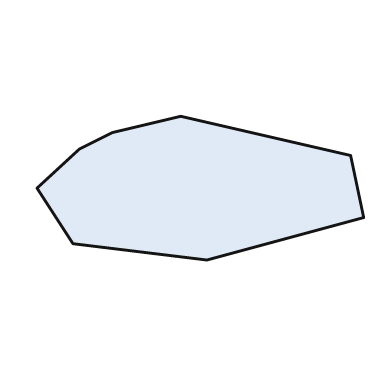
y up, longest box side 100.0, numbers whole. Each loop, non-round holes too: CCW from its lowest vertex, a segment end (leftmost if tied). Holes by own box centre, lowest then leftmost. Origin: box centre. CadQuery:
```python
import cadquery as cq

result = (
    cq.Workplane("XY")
    .moveTo(2.0, -22.0)
    .lineTo(50.0, -9.0)
    .lineTo(46.0, 10.0)
    .lineTo(-6.0, 22.0)
    .lineTo(-27.0, 17.0)
    .lineTo(-37.0, 12.0)
    .lineTo(-50.0, 0.0)
    .lineTo(-39.0, -17.0)
    .close()
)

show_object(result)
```